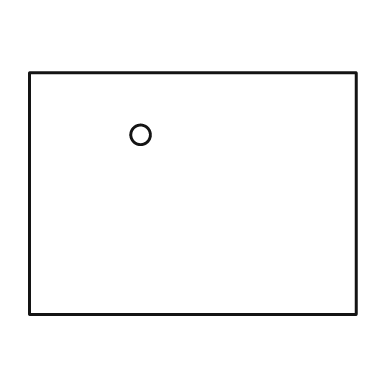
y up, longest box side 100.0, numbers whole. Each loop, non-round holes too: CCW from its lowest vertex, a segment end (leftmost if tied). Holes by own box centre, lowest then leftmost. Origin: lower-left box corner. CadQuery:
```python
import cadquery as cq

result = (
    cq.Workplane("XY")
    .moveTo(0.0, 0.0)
    .lineTo(100.0, 0.0)
    .lineTo(100.0, 74.0)
    .lineTo(0.0, 74.0)
    .close()
    .moveTo(34.0, 55.0)
    .circle(3.0)
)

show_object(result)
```